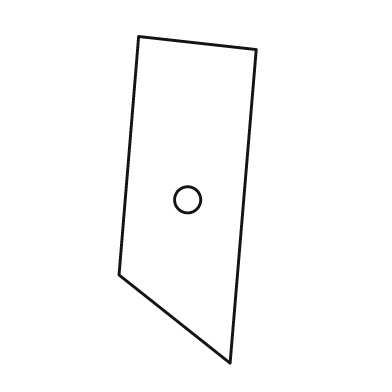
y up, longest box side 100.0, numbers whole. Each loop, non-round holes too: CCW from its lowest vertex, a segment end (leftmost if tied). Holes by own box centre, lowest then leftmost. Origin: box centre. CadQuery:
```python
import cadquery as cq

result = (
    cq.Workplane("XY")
    .moveTo(13.0, -50.0)
    .lineTo(21.0, 46.0)
    .lineTo(-15.0, 50.0)
    .lineTo(-21.0, -23.0)
    .close()
    .moveTo(0.0, 0.0)
    .circle(4.0)
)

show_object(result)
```